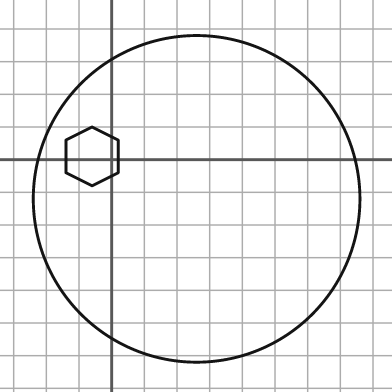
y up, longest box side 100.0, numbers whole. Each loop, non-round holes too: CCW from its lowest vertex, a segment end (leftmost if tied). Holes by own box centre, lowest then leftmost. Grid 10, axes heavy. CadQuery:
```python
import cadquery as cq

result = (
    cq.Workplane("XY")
    .moveTo(26.0, -12.0)
    .circle(50.0)
    .moveTo(-6.0, -8.0)
    .lineTo(2.0, -4.0)
    .lineTo(2.0, 6.0)
    .lineTo(-6.0, 10.0)
    .lineTo(-14.0, 6.0)
    .lineTo(-14.0, -4.0)
    .close()
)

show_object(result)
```